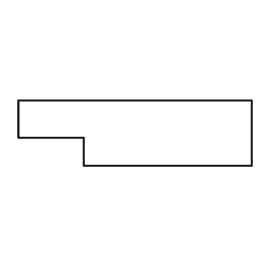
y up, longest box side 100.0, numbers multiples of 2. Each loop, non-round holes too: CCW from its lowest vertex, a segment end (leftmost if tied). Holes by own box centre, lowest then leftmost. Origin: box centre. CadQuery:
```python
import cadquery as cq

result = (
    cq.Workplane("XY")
    .moveTo(-22.0, -14.0)
    .lineTo(50.0, -14.0)
    .lineTo(50.0, 14.0)
    .lineTo(-50.0, 14.0)
    .lineTo(-50.0, -2.0)
    .lineTo(-22.0, -2.0)
    .close()
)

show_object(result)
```